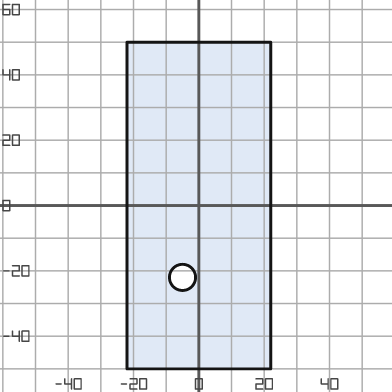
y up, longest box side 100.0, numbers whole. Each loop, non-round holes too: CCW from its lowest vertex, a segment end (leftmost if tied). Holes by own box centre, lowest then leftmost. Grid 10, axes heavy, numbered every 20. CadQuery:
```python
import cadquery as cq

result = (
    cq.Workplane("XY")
    .moveTo(-22.0, -50.0)
    .lineTo(22.0, -50.0)
    .lineTo(22.0, 50.0)
    .lineTo(-22.0, 50.0)
    .close()
    .moveTo(-5.0, -22.0)
    .circle(4.0)
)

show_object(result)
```